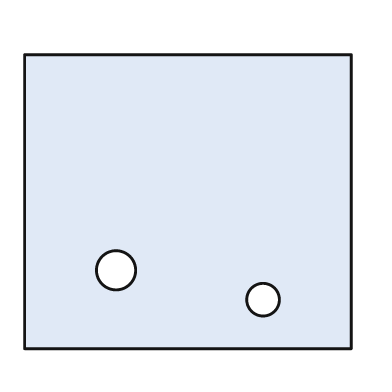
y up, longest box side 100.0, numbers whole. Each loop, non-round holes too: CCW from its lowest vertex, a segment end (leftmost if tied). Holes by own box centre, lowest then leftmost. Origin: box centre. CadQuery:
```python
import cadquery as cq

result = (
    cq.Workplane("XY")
    .moveTo(-50.0, -45.0)
    .lineTo(50.0, -45.0)
    .lineTo(50.0, 45.0)
    .lineTo(-50.0, 45.0)
    .close()
    .moveTo(23.0, -30.0)
    .circle(5.0)
    .moveTo(-22.0, -21.0)
    .circle(6.0)
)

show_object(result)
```